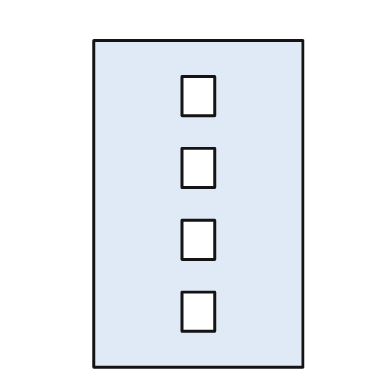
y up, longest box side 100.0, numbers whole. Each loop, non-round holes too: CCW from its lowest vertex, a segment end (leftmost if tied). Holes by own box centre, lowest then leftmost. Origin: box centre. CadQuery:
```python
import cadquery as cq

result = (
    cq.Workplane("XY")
    .moveTo(-32.0, -50.0)
    .lineTo(32.0, -50.0)
    .lineTo(32.0, 50.0)
    .lineTo(-32.0, 50.0)
    .close()
    .moveTo(-5.0, -39.0)
    .lineTo(5.0, -39.0)
    .lineTo(5.0, -27.0)
    .lineTo(-5.0, -27.0)
    .close()
    .moveTo(-5.0, -17.0)
    .lineTo(5.0, -17.0)
    .lineTo(5.0, -5.0)
    .lineTo(-5.0, -5.0)
    .close()
    .moveTo(-5.0, 5.0)
    .lineTo(5.0, 5.0)
    .lineTo(5.0, 17.0)
    .lineTo(-5.0, 17.0)
    .close()
    .moveTo(-5.0, 27.0)
    .lineTo(5.0, 27.0)
    .lineTo(5.0, 39.0)
    .lineTo(-5.0, 39.0)
    .close()
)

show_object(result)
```